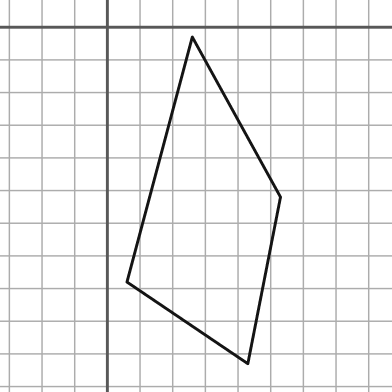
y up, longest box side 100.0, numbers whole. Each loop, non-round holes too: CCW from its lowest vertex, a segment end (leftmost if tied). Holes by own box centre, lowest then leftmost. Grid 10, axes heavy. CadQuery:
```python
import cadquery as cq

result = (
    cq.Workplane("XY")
    .moveTo(43.0, -103.0)
    .lineTo(53.0, -52.0)
    .lineTo(26.0, -3.0)
    .lineTo(6.0, -78.0)
    .close()
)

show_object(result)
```